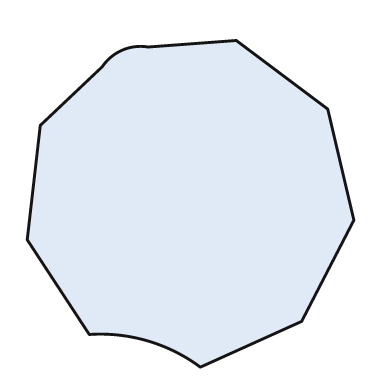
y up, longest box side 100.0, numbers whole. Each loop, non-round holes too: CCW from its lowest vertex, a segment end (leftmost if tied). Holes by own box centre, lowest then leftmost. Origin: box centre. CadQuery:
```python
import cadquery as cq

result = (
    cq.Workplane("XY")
    .moveTo(3.0, -50.0)
    .lineTo(34.0, -36.0)
    .lineTo(50.0, -5.0)
    .lineTo(42.0, 29.0)
    .lineTo(14.0, 50.0)
    .lineTo(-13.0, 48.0)
    .threePointArc((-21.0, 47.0), (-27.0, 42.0))
    .lineTo(-46.0, 24.0)
    .lineTo(-50.0, -11.0)
    .lineTo(-31.0, -40.0)
    .threePointArc((-13.0, -42.0), (3.0, -50.0))
    .close()
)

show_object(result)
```